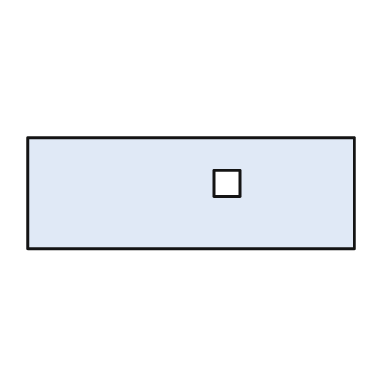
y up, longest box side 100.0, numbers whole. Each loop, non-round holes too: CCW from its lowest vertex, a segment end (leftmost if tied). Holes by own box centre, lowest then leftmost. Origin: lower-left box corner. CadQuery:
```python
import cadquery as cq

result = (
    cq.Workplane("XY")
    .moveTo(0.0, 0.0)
    .lineTo(100.0, 0.0)
    .lineTo(100.0, 34.0)
    .lineTo(0.0, 34.0)
    .close()
    .moveTo(57.0, 16.0)
    .lineTo(65.0, 16.0)
    .lineTo(65.0, 24.0)
    .lineTo(57.0, 24.0)
    .close()
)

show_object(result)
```